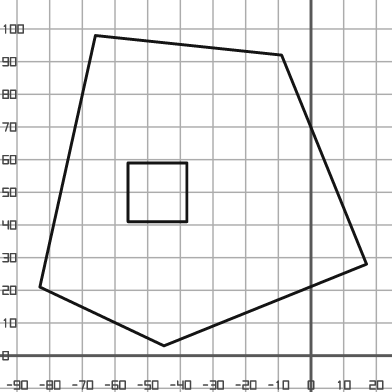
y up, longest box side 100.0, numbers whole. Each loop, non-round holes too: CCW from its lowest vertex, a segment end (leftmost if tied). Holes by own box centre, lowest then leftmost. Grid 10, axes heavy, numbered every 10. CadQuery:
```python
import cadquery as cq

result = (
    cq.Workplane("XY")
    .moveTo(-45.0, 3.0)
    .lineTo(17.0, 28.0)
    .lineTo(-9.0, 92.0)
    .lineTo(-66.0, 98.0)
    .lineTo(-83.0, 21.0)
    .close()
    .moveTo(-56.0, 41.0)
    .lineTo(-38.0, 41.0)
    .lineTo(-38.0, 59.0)
    .lineTo(-56.0, 59.0)
    .close()
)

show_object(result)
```